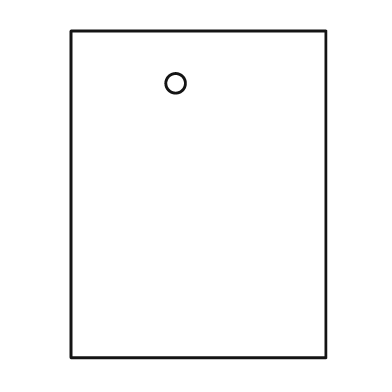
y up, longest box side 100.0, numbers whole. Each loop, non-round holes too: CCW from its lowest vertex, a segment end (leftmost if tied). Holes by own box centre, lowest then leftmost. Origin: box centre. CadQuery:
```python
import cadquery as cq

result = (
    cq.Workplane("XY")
    .moveTo(-39.0, -50.0)
    .lineTo(39.0, -50.0)
    .lineTo(39.0, 50.0)
    .lineTo(-39.0, 50.0)
    .close()
    .moveTo(-7.0, 34.0)
    .circle(3.0)
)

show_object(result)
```